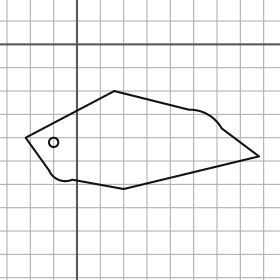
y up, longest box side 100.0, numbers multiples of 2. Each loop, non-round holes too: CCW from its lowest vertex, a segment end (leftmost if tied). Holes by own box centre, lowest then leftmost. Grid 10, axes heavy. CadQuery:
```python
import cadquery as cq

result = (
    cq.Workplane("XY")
    .moveTo(20.0, -62.0)
    .lineTo(78.0, -48.0)
    .lineTo(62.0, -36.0)
    .threePointArc((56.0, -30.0), (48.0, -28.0))
    .lineTo(16.0, -20.0)
    .lineTo(-22.0, -40.0)
    .lineTo(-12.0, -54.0)
    .threePointArc((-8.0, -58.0), (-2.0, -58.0))
    .close()
    .moveTo(-10.0, -42.0)
    .circle(2.0)
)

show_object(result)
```